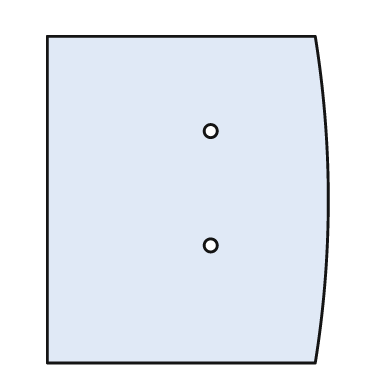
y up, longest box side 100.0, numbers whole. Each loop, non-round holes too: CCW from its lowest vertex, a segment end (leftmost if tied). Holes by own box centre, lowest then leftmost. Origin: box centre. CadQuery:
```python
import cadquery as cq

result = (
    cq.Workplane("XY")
    .moveTo(-43.0, -50.0)
    .lineTo(39.0, -50.0)
    .threePointArc((43.0, 0.0), (39.0, 50.0))
    .lineTo(-43.0, 50.0)
    .close()
    .moveTo(7.0, -14.0)
    .circle(2.0)
    .moveTo(7.0, 21.0)
    .circle(2.0)
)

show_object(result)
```